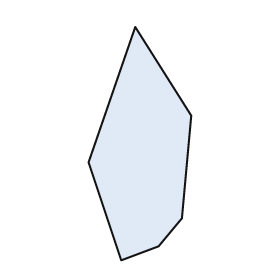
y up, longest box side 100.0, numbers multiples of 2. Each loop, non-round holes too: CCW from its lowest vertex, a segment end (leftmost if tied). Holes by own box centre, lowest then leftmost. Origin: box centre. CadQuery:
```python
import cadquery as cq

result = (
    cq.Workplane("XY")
    .moveTo(-8.0, -50.0)
    .lineTo(8.0, -44.0)
    .lineTo(18.0, -32.0)
    .lineTo(22.0, 12.0)
    .lineTo(-2.0, 50.0)
    .lineTo(-22.0, -8.0)
    .close()
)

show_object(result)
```